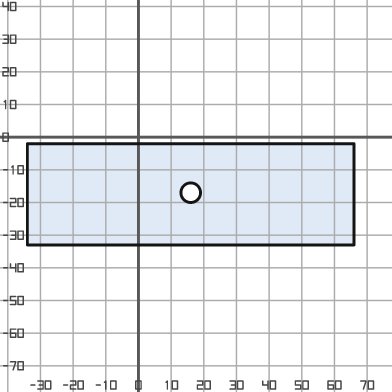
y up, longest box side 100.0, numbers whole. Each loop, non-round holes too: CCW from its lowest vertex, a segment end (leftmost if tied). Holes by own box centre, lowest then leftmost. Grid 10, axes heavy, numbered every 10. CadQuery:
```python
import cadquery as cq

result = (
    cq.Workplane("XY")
    .moveTo(-34.0, -33.0)
    .lineTo(66.0, -33.0)
    .lineTo(66.0, -2.0)
    .lineTo(-34.0, -2.0)
    .close()
    .moveTo(16.0, -17.0)
    .circle(3.0)
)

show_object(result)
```